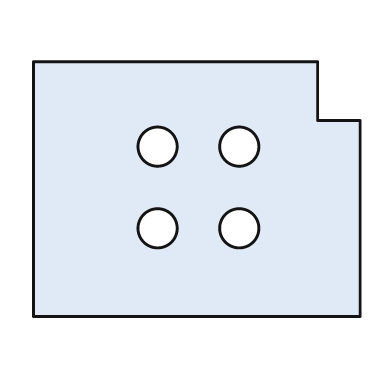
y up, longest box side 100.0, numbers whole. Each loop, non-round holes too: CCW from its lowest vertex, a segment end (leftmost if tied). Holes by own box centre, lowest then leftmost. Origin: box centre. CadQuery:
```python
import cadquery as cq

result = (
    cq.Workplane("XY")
    .moveTo(-50.0, -39.0)
    .lineTo(50.0, -39.0)
    .lineTo(50.0, 21.0)
    .lineTo(37.0, 21.0)
    .lineTo(37.0, 39.0)
    .lineTo(-50.0, 39.0)
    .close()
    .moveTo(-12.0, -12.0)
    .circle(6.0)
    .moveTo(13.0, -12.0)
    .circle(6.0)
    .moveTo(-12.0, 13.0)
    .circle(6.0)
    .moveTo(13.0, 13.0)
    .circle(6.0)
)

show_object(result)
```